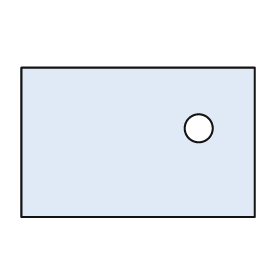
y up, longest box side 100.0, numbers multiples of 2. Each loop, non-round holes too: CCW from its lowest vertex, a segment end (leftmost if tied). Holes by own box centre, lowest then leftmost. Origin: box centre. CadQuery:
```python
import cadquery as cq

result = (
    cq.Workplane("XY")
    .moveTo(-50.0, -32.0)
    .lineTo(50.0, -32.0)
    .lineTo(50.0, 32.0)
    .lineTo(-50.0, 32.0)
    .close()
    .moveTo(26.0, 6.0)
    .circle(6.0)
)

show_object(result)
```